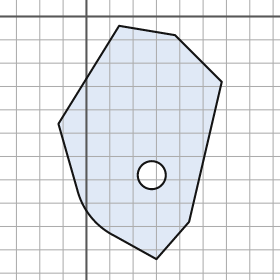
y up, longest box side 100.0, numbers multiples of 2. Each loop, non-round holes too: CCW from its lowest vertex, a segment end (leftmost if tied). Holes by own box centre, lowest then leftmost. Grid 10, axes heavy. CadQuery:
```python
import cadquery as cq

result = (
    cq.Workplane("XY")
    .moveTo(30.0, -104.0)
    .lineTo(44.0, -88.0)
    .lineTo(58.0, -28.0)
    .lineTo(38.0, -8.0)
    .lineTo(14.0, -4.0)
    .lineTo(-12.0, -46.0)
    .lineTo(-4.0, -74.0)
    .threePointArc((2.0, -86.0), (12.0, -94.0))
    .close()
    .moveTo(28.0, -68.0)
    .circle(6.0)
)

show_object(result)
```